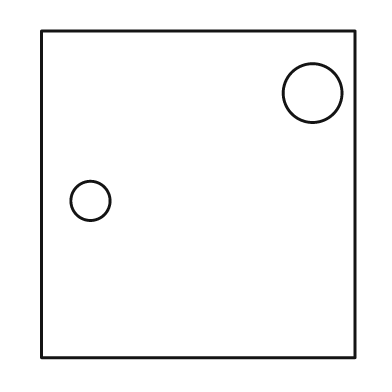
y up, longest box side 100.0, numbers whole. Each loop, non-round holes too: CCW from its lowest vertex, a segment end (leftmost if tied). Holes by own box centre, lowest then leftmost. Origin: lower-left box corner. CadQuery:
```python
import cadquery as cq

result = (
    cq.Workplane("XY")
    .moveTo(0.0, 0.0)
    .lineTo(96.0, 0.0)
    .lineTo(96.0, 100.0)
    .lineTo(0.0, 100.0)
    .close()
    .moveTo(15.0, 48.0)
    .circle(6.0)
    .moveTo(83.0, 81.0)
    .circle(9.0)
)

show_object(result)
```